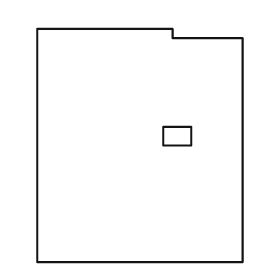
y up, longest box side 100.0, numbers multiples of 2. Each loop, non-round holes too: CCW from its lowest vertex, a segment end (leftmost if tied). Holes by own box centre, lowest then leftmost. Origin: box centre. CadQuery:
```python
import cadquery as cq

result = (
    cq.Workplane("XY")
    .moveTo(-44.0, -50.0)
    .lineTo(44.0, -50.0)
    .lineTo(44.0, 46.0)
    .lineTo(14.0, 46.0)
    .lineTo(14.0, 50.0)
    .lineTo(-44.0, 50.0)
    .close()
    .moveTo(10.0, 0.0)
    .lineTo(22.0, 0.0)
    .lineTo(22.0, 8.0)
    .lineTo(10.0, 8.0)
    .close()
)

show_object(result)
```